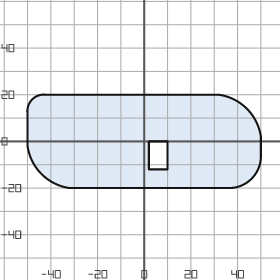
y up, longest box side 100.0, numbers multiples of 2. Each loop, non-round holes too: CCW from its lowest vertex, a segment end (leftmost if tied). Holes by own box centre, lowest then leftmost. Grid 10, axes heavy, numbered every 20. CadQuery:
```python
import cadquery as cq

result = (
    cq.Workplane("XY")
    .moveTo(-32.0, -20.0)
    .lineTo(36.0, -20.0)
    .threePointArc((46.0, -16.0), (50.0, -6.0))
    .lineTo(50.0, 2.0)
    .threePointArc((44.0, 14.0), (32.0, 20.0))
    .lineTo(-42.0, 20.0)
    .threePointArc((-48.0, 18.0), (-50.0, 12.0))
    .lineTo(-50.0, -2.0)
    .threePointArc((-44.0, -14.0), (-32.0, -20.0))
    .close()
    .moveTo(2.0, -12.0)
    .lineTo(10.0, -12.0)
    .lineTo(10.0, 0.0)
    .lineTo(2.0, 0.0)
    .close()
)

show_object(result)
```